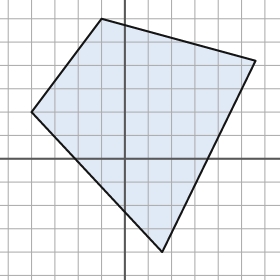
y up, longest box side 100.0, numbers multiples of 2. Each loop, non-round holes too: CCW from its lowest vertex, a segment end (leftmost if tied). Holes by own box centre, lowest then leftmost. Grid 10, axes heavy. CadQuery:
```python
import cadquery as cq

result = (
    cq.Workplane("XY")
    .moveTo(16.0, -40.0)
    .lineTo(56.0, 42.0)
    .lineTo(-10.0, 60.0)
    .lineTo(-40.0, 20.0)
    .close()
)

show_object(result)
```